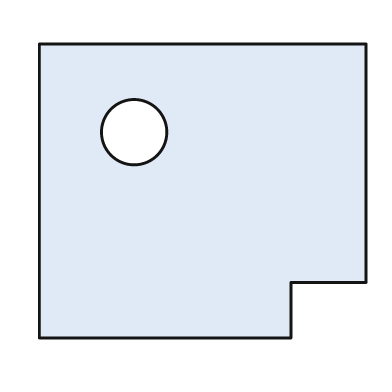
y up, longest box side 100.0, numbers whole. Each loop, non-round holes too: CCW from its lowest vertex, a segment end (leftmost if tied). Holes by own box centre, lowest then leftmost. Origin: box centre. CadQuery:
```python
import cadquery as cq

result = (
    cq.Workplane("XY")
    .moveTo(-50.0, -45.0)
    .lineTo(27.0, -45.0)
    .lineTo(27.0, -28.0)
    .lineTo(50.0, -28.0)
    .lineTo(50.0, 45.0)
    .lineTo(-50.0, 45.0)
    .close()
    .moveTo(-21.0, 18.0)
    .circle(10.0)
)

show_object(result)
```